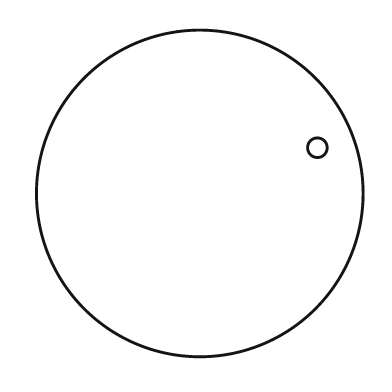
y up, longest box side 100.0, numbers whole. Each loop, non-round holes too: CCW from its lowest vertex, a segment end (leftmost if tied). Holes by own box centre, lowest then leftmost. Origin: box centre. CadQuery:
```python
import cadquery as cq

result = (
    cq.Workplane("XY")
    .moveTo(0.0, 0.0)
    .circle(50.0)
    .moveTo(36.0, 14.0)
    .circle(3.0)
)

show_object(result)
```